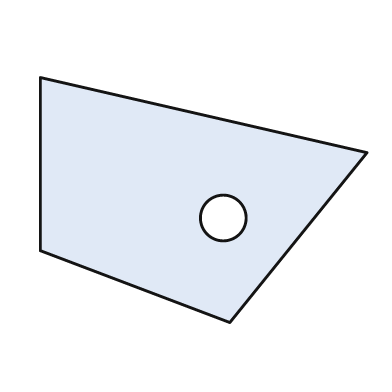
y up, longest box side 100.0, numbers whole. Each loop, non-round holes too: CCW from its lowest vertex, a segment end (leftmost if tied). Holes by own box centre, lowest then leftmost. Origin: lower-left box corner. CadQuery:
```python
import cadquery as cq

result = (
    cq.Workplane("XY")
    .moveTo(58.0, 0.0)
    .lineTo(100.0, 52.0)
    .lineTo(0.0, 75.0)
    .lineTo(0.0, 22.0)
    .close()
    .moveTo(56.0, 32.0)
    .circle(7.0)
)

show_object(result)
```